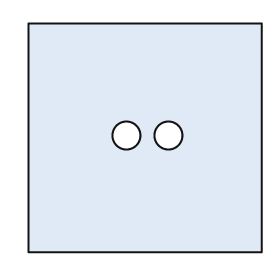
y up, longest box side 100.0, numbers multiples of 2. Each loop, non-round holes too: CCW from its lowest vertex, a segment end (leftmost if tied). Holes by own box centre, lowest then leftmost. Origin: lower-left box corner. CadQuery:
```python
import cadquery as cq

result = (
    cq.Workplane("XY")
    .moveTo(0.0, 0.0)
    .lineTo(100.0, 0.0)
    .lineTo(100.0, 98.0)
    .lineTo(0.0, 98.0)
    .close()
    .moveTo(42.0, 50.0)
    .circle(6.0)
    .moveTo(60.0, 50.0)
    .circle(6.0)
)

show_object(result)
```